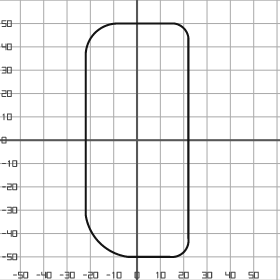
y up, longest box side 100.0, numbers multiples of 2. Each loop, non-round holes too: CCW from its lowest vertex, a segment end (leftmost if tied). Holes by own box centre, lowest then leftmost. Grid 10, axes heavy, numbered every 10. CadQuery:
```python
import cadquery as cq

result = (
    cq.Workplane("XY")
    .moveTo(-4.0, -50.0)
    .lineTo(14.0, -50.0)
    .threePointArc((20.0, -48.0), (22.0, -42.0))
    .lineTo(22.0, 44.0)
    .threePointArc((20.0, 48.0), (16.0, 50.0))
    .lineTo(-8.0, 50.0)
    .threePointArc((-18.0, 46.0), (-22.0, 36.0))
    .lineTo(-22.0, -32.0)
    .threePointArc((-16.0, -44.0), (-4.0, -50.0))
    .close()
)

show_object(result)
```